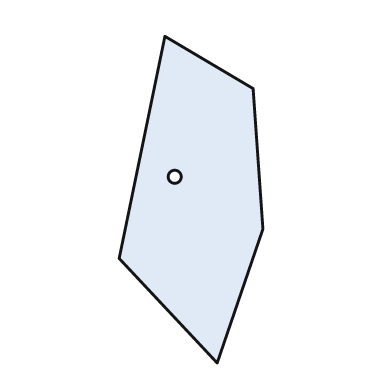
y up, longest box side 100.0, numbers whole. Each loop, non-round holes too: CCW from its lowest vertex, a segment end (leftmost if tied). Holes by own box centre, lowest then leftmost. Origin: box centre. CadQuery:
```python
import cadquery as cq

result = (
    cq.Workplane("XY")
    .moveTo(8.0, -50.0)
    .lineTo(22.0, -9.0)
    .lineTo(19.0, 34.0)
    .lineTo(-8.0, 50.0)
    .lineTo(-22.0, -18.0)
    .close()
    .moveTo(-5.0, 7.0)
    .circle(2.0)
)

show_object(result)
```